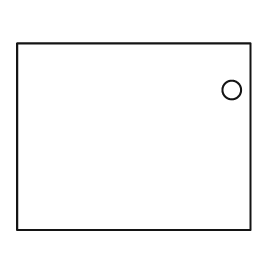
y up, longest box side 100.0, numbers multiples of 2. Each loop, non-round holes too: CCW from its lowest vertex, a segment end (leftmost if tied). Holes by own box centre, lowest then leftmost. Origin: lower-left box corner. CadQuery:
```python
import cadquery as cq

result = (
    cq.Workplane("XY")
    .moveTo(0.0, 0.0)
    .lineTo(100.0, 0.0)
    .lineTo(100.0, 80.0)
    .lineTo(0.0, 80.0)
    .close()
    .moveTo(92.0, 60.0)
    .circle(4.0)
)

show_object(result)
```